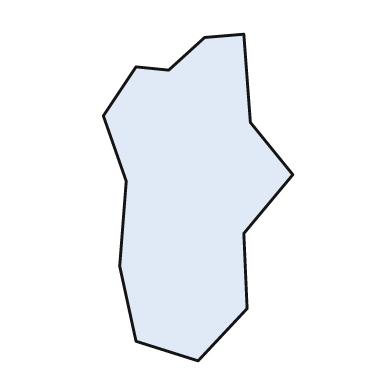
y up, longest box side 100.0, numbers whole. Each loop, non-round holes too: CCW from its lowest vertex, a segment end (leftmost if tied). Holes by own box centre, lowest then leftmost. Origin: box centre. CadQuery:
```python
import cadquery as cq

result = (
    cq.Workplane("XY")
    .moveTo(0.0, -50.0)
    .lineTo(15.0, -34.0)
    .lineTo(14.0, -11.0)
    .lineTo(29.0, 7.0)
    .lineTo(16.0, 23.0)
    .lineTo(14.0, 50.0)
    .lineTo(2.0, 49.0)
    .lineTo(-9.0, 39.0)
    .lineTo(-19.0, 40.0)
    .lineTo(-29.0, 25.0)
    .lineTo(-22.0, 5.0)
    .lineTo(-24.0, -21.0)
    .lineTo(-19.0, -44.0)
    .close()
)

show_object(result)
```